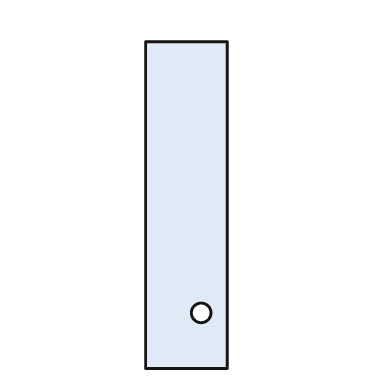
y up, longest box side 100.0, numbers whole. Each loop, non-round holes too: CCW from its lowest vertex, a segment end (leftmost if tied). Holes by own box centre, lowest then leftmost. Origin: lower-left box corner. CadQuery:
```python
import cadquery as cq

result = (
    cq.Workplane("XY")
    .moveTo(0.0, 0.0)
    .lineTo(25.0, 0.0)
    .lineTo(25.0, 100.0)
    .lineTo(0.0, 100.0)
    .close()
    .moveTo(17.0, 17.0)
    .circle(3.0)
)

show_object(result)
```